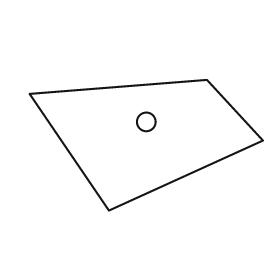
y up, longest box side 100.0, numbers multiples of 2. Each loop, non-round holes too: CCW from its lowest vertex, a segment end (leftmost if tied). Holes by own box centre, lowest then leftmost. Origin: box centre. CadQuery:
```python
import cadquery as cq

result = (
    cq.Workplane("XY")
    .moveTo(-16.0, -28.0)
    .lineTo(50.0, 2.0)
    .lineTo(26.0, 28.0)
    .lineTo(-50.0, 22.0)
    .close()
    .moveTo(0.0, 10.0)
    .circle(4.0)
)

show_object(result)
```